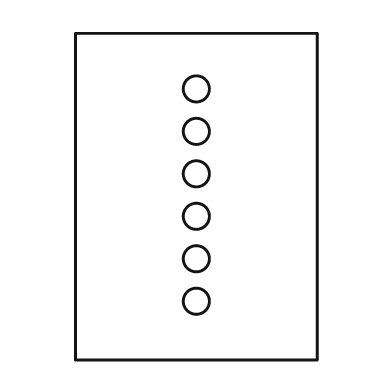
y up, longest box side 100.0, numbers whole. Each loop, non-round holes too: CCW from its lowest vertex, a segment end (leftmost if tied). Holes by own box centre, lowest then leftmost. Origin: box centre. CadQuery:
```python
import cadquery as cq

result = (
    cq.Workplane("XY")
    .moveTo(-37.0, -50.0)
    .lineTo(37.0, -50.0)
    .lineTo(37.0, 50.0)
    .lineTo(-37.0, 50.0)
    .close()
    .moveTo(0.0, -32.0)
    .circle(4.0)
    .moveTo(0.0, -19.0)
    .circle(4.0)
    .moveTo(0.0, -6.0)
    .circle(4.0)
    .moveTo(0.0, 7.0)
    .circle(4.0)
    .moveTo(0.0, 20.0)
    .circle(4.0)
    .moveTo(0.0, 33.0)
    .circle(4.0)
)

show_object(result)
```